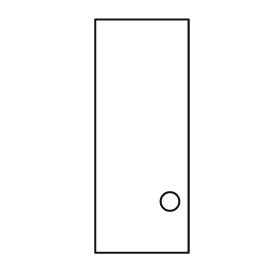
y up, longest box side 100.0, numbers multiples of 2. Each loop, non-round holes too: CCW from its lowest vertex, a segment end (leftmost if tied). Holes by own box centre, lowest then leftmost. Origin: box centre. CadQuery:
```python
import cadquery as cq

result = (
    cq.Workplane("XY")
    .moveTo(-20.0, -50.0)
    .lineTo(20.0, -50.0)
    .lineTo(20.0, 50.0)
    .lineTo(-20.0, 50.0)
    .close()
    .moveTo(12.0, -28.0)
    .circle(4.0)
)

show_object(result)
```